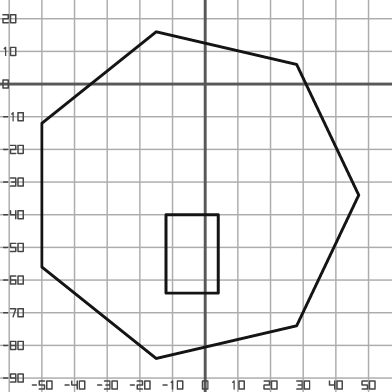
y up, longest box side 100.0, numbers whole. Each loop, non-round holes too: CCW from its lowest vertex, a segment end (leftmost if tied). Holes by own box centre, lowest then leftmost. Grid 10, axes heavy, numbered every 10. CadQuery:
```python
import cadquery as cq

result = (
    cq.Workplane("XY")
    .moveTo(-15.0, -84.0)
    .lineTo(28.0, -74.0)
    .lineTo(47.0, -34.0)
    .lineTo(28.0, 6.0)
    .lineTo(-15.0, 16.0)
    .lineTo(-50.0, -12.0)
    .lineTo(-50.0, -56.0)
    .close()
    .moveTo(-12.0, -64.0)
    .lineTo(4.0, -64.0)
    .lineTo(4.0, -40.0)
    .lineTo(-12.0, -40.0)
    .close()
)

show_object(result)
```